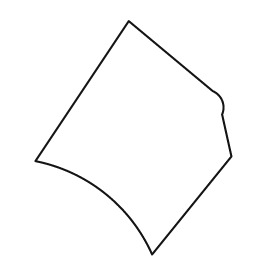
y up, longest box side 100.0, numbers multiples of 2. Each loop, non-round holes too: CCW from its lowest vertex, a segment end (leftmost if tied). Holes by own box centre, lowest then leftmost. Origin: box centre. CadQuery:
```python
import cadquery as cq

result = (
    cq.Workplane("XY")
    .moveTo(8.0, -50.0)
    .lineTo(42.0, -8.0)
    .lineTo(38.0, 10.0)
    .threePointArc((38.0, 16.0), (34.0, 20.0))
    .lineTo(-2.0, 50.0)
    .lineTo(-42.0, -10.0)
    .threePointArc((-12.0, -24.0), (8.0, -50.0))
    .close()
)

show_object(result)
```